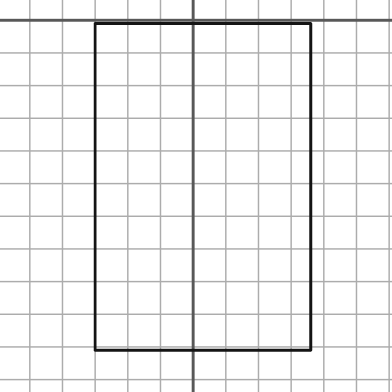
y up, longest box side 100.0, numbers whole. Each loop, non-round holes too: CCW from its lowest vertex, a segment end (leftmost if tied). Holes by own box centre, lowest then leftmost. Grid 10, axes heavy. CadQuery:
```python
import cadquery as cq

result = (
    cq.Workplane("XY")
    .moveTo(-30.0, -101.0)
    .lineTo(36.0, -101.0)
    .lineTo(36.0, -1.0)
    .lineTo(-30.0, -1.0)
    .close()
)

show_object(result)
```